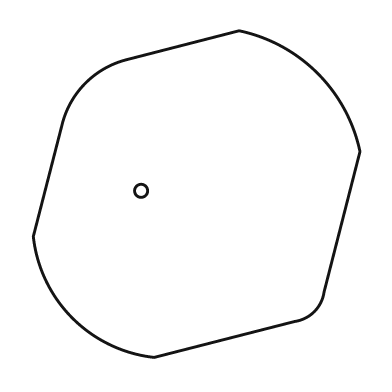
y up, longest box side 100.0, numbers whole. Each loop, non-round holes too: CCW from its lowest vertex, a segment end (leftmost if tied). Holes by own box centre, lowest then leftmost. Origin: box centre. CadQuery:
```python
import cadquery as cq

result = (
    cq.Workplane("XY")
    .moveTo(-13.0, -50.0)
    .lineTo(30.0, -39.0)
    .threePointArc((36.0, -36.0), (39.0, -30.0))
    .lineTo(50.0, 13.0)
    .threePointArc((37.0, 37.0), (13.0, 50.0))
    .lineTo(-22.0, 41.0)
    .threePointArc((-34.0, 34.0), (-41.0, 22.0))
    .lineTo(-50.0, -13.0)
    .threePointArc((-38.0, -38.0), (-13.0, -50.0))
    .close()
    .moveTo(-17.0, 1.0)
    .circle(2.0)
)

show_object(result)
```